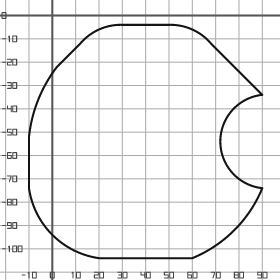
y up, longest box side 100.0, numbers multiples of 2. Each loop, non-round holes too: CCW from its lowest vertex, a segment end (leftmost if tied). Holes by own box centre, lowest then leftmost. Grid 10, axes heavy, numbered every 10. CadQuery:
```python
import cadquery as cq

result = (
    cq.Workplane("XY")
    .moveTo(20.0, -104.0)
    .lineTo(60.0, -104.0)
    .threePointArc((78.0, -92.0), (90.0, -74.0))
    .threePointArc((72.0, -54.0), (90.0, -34.0))
    .lineTo(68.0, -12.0)
    .threePointArc((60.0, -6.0), (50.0, -4.0))
    .lineTo(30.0, -4.0)
    .threePointArc((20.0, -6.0), (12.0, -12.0))
    .lineTo(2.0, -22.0)
    .threePointArc((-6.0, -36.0), (-10.0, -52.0))
    .lineTo(-10.0, -74.0)
    .threePointArc((0.0, -94.0), (20.0, -104.0))
    .close()
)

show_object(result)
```